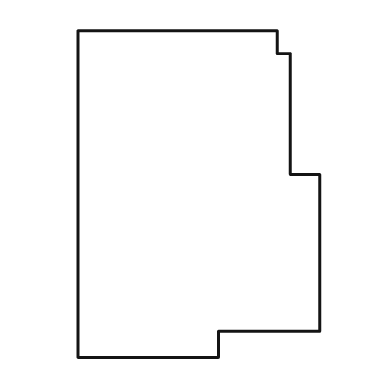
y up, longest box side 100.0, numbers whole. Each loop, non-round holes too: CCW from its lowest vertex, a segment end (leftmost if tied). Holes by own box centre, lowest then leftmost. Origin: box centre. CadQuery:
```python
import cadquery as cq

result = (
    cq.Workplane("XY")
    .moveTo(-37.0, -50.0)
    .lineTo(6.0, -50.0)
    .lineTo(6.0, -42.0)
    .lineTo(37.0, -42.0)
    .lineTo(37.0, 6.0)
    .lineTo(28.0, 6.0)
    .lineTo(28.0, 43.0)
    .lineTo(24.0, 43.0)
    .lineTo(24.0, 50.0)
    .lineTo(-37.0, 50.0)
    .close()
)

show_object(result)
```